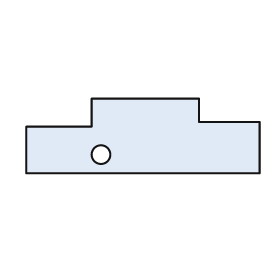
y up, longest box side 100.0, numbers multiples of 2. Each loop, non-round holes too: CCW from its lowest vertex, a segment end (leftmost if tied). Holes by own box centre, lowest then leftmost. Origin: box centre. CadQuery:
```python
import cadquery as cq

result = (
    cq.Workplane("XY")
    .moveTo(-50.0, -16.0)
    .lineTo(50.0, -16.0)
    .lineTo(50.0, 6.0)
    .lineTo(24.0, 6.0)
    .lineTo(24.0, 16.0)
    .lineTo(-22.0, 16.0)
    .lineTo(-22.0, 4.0)
    .lineTo(-50.0, 4.0)
    .close()
    .moveTo(-18.0, -8.0)
    .circle(4.0)
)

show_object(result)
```